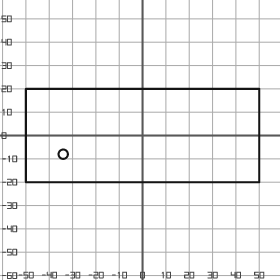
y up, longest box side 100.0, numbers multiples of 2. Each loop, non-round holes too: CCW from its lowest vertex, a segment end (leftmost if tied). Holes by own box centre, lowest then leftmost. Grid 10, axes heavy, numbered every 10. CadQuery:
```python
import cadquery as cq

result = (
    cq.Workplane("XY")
    .moveTo(-50.0, -20.0)
    .lineTo(50.0, -20.0)
    .lineTo(50.0, 20.0)
    .lineTo(-50.0, 20.0)
    .close()
    .moveTo(-34.0, -8.0)
    .circle(2.0)
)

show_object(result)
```